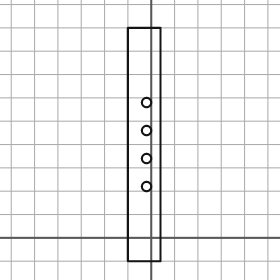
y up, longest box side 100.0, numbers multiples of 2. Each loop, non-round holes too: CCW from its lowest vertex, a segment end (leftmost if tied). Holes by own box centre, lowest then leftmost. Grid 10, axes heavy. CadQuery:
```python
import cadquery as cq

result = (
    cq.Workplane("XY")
    .moveTo(-10.0, -10.0)
    .lineTo(4.0, -10.0)
    .lineTo(4.0, 90.0)
    .lineTo(-10.0, 90.0)
    .close()
    .moveTo(-2.0, 22.0)
    .circle(2.0)
    .moveTo(-2.0, 34.0)
    .circle(2.0)
    .moveTo(-2.0, 46.0)
    .circle(2.0)
    .moveTo(-2.0, 58.0)
    .circle(2.0)
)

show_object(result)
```